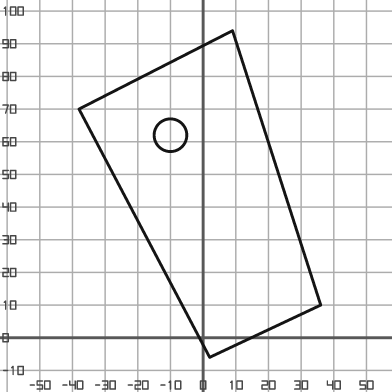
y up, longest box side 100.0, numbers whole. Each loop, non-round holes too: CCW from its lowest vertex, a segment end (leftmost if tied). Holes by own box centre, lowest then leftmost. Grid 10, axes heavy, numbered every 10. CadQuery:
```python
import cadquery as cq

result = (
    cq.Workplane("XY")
    .moveTo(2.0, -6.0)
    .lineTo(36.0, 10.0)
    .lineTo(9.0, 94.0)
    .lineTo(-38.0, 70.0)
    .close()
    .moveTo(-10.0, 62.0)
    .circle(5.0)
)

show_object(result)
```